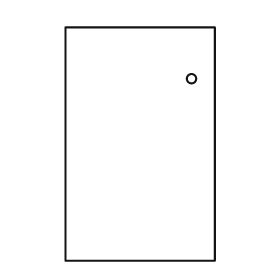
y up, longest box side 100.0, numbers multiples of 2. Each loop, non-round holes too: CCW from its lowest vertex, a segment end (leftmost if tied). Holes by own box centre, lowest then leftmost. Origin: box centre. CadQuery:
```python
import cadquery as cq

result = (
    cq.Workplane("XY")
    .moveTo(-32.0, -50.0)
    .lineTo(32.0, -50.0)
    .lineTo(32.0, 50.0)
    .lineTo(-32.0, 50.0)
    .close()
    .moveTo(22.0, 28.0)
    .circle(2.0)
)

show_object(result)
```